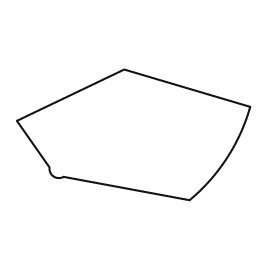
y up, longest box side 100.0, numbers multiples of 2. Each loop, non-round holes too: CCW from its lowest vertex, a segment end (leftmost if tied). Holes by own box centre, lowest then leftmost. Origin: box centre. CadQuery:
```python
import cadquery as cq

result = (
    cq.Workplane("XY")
    .moveTo(24.0, -28.0)
    .threePointArc((40.0, -10.0), (50.0, 12.0))
    .lineTo(-4.0, 28.0)
    .lineTo(-50.0, 6.0)
    .lineTo(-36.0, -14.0)
    .threePointArc((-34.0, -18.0), (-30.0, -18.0))
    .close()
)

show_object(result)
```